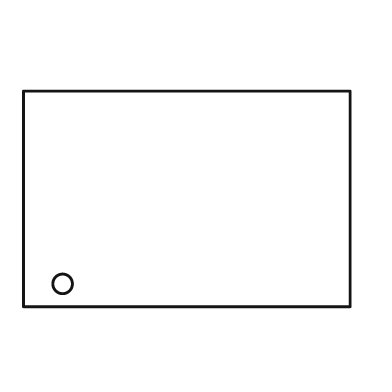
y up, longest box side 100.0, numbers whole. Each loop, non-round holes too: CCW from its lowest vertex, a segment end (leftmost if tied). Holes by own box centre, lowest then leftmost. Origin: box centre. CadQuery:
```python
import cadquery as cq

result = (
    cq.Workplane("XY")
    .moveTo(-50.0, -33.0)
    .lineTo(50.0, -33.0)
    .lineTo(50.0, 33.0)
    .lineTo(-50.0, 33.0)
    .close()
    .moveTo(-38.0, -26.0)
    .circle(3.0)
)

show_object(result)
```